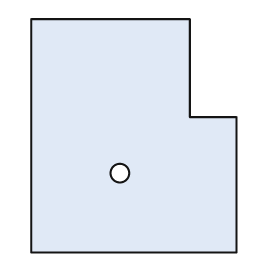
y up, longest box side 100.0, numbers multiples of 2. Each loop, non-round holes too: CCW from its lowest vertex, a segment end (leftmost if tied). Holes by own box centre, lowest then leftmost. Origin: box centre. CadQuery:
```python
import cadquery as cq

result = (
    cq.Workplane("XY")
    .moveTo(-44.0, -50.0)
    .lineTo(44.0, -50.0)
    .lineTo(44.0, 8.0)
    .lineTo(24.0, 8.0)
    .lineTo(24.0, 50.0)
    .lineTo(-44.0, 50.0)
    .close()
    .moveTo(-6.0, -16.0)
    .circle(4.0)
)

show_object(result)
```